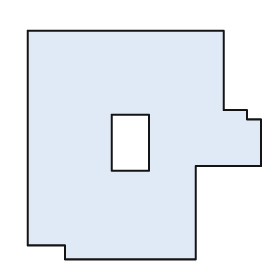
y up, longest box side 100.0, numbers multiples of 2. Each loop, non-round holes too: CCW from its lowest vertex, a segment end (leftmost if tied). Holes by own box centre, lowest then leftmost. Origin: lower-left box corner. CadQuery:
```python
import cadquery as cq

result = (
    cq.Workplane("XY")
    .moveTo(16.0, 0.0)
    .lineTo(72.0, 0.0)
    .lineTo(72.0, 40.0)
    .lineTo(100.0, 40.0)
    .lineTo(100.0, 60.0)
    .lineTo(94.0, 60.0)
    .lineTo(94.0, 64.0)
    .lineTo(84.0, 64.0)
    .lineTo(84.0, 98.0)
    .lineTo(0.0, 98.0)
    .lineTo(0.0, 6.0)
    .lineTo(16.0, 6.0)
    .close()
    .moveTo(36.0, 38.0)
    .lineTo(52.0, 38.0)
    .lineTo(52.0, 62.0)
    .lineTo(36.0, 62.0)
    .close()
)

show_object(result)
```